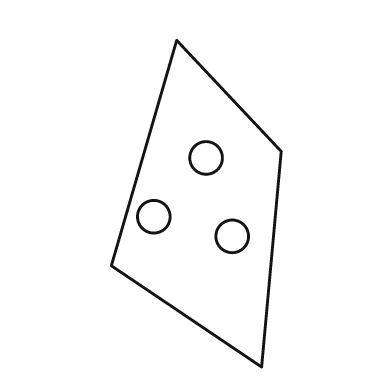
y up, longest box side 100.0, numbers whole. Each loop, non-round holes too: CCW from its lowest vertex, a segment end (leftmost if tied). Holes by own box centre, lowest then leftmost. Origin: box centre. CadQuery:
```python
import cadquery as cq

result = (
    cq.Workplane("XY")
    .moveTo(20.0, -50.0)
    .lineTo(26.0, 16.0)
    .lineTo(-6.0, 50.0)
    .lineTo(-26.0, -19.0)
    .close()
    .moveTo(11.0, -10.0)
    .circle(5.0)
    .moveTo(-13.0, -4.0)
    .circle(5.0)
    .moveTo(3.0, 14.0)
    .circle(5.0)
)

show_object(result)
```